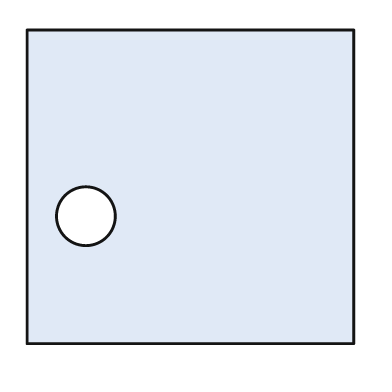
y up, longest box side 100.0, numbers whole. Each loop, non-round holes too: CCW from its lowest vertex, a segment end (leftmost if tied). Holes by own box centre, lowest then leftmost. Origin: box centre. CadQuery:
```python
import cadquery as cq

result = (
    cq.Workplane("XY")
    .moveTo(-50.0, -48.0)
    .lineTo(50.0, -48.0)
    .lineTo(50.0, 48.0)
    .lineTo(-50.0, 48.0)
    .close()
    .moveTo(-32.0, -9.0)
    .circle(9.0)
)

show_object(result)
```